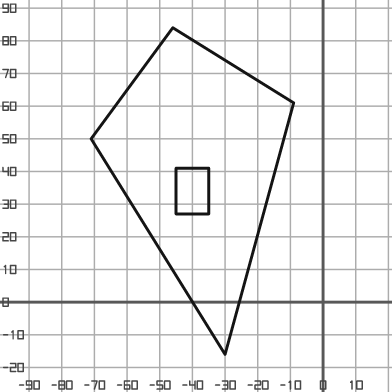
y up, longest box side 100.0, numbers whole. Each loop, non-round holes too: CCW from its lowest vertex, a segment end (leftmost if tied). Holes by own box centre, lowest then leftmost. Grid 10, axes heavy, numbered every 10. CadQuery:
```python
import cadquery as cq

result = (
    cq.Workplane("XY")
    .moveTo(-30.0, -16.0)
    .lineTo(-9.0, 61.0)
    .lineTo(-46.0, 84.0)
    .lineTo(-71.0, 50.0)
    .close()
    .moveTo(-45.0, 27.0)
    .lineTo(-35.0, 27.0)
    .lineTo(-35.0, 41.0)
    .lineTo(-45.0, 41.0)
    .close()
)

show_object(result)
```